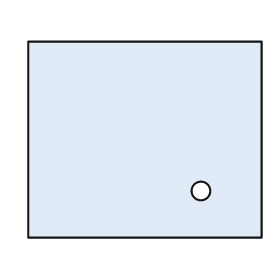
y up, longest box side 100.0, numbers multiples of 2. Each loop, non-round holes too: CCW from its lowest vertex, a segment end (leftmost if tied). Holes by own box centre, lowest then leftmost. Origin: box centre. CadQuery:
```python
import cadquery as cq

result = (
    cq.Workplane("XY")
    .moveTo(-50.0, -42.0)
    .lineTo(50.0, -42.0)
    .lineTo(50.0, 42.0)
    .lineTo(-50.0, 42.0)
    .close()
    .moveTo(24.0, -22.0)
    .circle(4.0)
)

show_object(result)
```